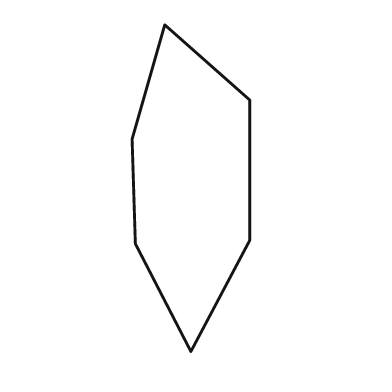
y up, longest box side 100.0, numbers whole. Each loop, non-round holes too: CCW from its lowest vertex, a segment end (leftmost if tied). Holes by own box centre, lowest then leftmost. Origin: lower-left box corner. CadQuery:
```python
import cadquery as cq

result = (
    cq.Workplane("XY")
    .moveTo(18.0, 0.0)
    .lineTo(36.0, 34.0)
    .lineTo(36.0, 77.0)
    .lineTo(10.0, 100.0)
    .lineTo(0.0, 65.0)
    .lineTo(1.0, 33.0)
    .close()
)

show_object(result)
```